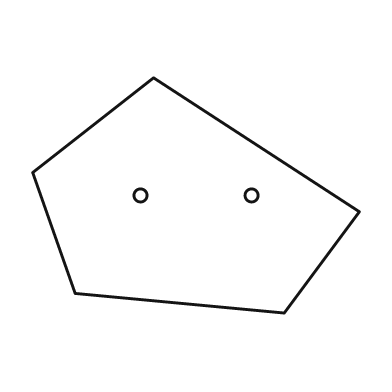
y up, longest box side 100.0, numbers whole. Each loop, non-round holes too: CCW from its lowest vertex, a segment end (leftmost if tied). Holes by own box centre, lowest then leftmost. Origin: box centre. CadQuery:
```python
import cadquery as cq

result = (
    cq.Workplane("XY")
    .moveTo(27.0, -36.0)
    .lineTo(50.0, -5.0)
    .lineTo(-13.0, 36.0)
    .lineTo(-50.0, 7.0)
    .lineTo(-37.0, -30.0)
    .close()
    .moveTo(-17.0, 0.0)
    .circle(2.0)
    .moveTo(17.0, 0.0)
    .circle(2.0)
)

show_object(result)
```